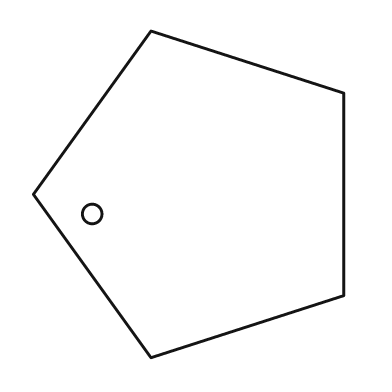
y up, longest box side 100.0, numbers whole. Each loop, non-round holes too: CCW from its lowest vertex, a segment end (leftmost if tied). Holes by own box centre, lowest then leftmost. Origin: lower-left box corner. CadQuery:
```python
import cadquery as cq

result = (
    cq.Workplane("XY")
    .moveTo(36.0, 0.0)
    .lineTo(95.0, 19.0)
    .lineTo(95.0, 81.0)
    .lineTo(36.0, 100.0)
    .lineTo(0.0, 50.0)
    .close()
    .moveTo(18.0, 44.0)
    .circle(3.0)
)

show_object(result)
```